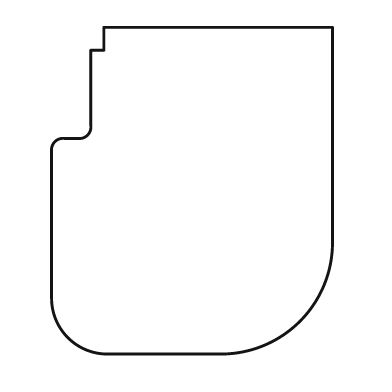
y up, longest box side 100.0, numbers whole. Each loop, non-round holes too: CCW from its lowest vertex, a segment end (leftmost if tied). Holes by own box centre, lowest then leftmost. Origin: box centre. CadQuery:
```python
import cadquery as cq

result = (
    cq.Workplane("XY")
    .moveTo(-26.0, -50.0)
    .lineTo(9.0, -50.0)
    .threePointArc((33.0, -40.0), (43.0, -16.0))
    .lineTo(43.0, 50.0)
    .lineTo(-27.0, 50.0)
    .lineTo(-27.0, 43.0)
    .lineTo(-31.0, 43.0)
    .lineTo(-31.0, 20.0)
    .threePointArc((-32.0, 17.0), (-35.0, 16.0))
    .lineTo(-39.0, 16.0)
    .threePointArc((-42.0, 15.0), (-43.0, 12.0))
    .lineTo(-43.0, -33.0)
    .threePointArc((-38.0, -45.0), (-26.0, -50.0))
    .close()
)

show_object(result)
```